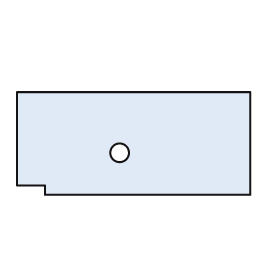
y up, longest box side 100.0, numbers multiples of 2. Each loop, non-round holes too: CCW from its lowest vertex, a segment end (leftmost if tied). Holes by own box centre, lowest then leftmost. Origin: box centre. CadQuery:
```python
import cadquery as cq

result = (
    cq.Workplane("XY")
    .moveTo(-38.0, -22.0)
    .lineTo(50.0, -22.0)
    .lineTo(50.0, 22.0)
    .lineTo(-50.0, 22.0)
    .lineTo(-50.0, -18.0)
    .lineTo(-38.0, -18.0)
    .close()
    .moveTo(-6.0, -4.0)
    .circle(4.0)
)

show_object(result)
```